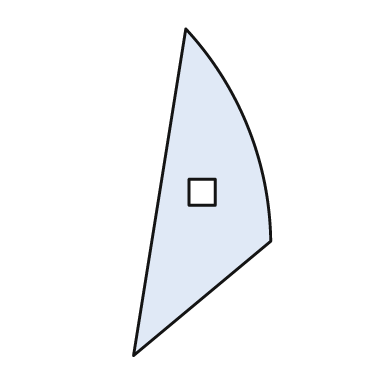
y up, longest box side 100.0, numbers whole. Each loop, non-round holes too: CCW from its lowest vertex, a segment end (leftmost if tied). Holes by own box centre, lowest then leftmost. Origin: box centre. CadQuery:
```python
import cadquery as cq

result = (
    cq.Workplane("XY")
    .moveTo(-21.0, -50.0)
    .lineTo(21.0, -15.0)
    .threePointArc((14.0, 20.0), (-5.0, 50.0))
    .close()
    .moveTo(-4.0, -4.0)
    .lineTo(4.0, -4.0)
    .lineTo(4.0, 4.0)
    .lineTo(-4.0, 4.0)
    .close()
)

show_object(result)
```